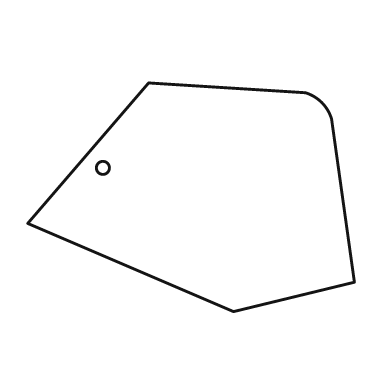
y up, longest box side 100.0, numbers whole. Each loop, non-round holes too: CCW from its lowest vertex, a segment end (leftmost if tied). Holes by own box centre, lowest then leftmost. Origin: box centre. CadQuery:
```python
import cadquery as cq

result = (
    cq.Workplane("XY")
    .moveTo(13.0, -35.0)
    .lineTo(50.0, -26.0)
    .lineTo(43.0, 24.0)
    .threePointArc((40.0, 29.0), (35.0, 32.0))
    .lineTo(-13.0, 35.0)
    .lineTo(-50.0, -8.0)
    .close()
    .moveTo(-27.0, 9.0)
    .circle(2.0)
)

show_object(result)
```